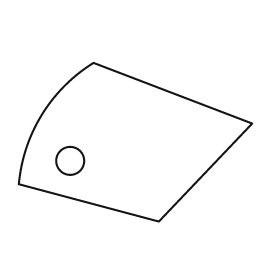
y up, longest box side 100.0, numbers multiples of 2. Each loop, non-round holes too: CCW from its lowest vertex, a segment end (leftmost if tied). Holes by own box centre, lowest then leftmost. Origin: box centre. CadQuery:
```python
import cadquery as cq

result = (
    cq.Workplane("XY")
    .moveTo(10.0, -34.0)
    .lineTo(50.0, 8.0)
    .lineTo(-18.0, 34.0)
    .threePointArc((-40.0, 12.0), (-50.0, -18.0))
    .close()
    .moveTo(-28.0, -8.0)
    .circle(6.0)
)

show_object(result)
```